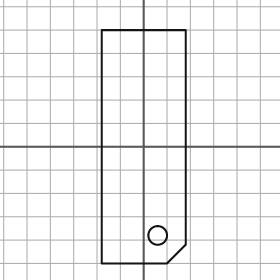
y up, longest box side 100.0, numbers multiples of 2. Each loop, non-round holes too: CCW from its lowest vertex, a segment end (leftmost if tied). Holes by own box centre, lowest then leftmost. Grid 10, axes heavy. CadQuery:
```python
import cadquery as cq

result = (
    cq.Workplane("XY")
    .moveTo(-18.0, -50.0)
    .lineTo(10.0, -50.0)
    .lineTo(18.0, -42.0)
    .lineTo(18.0, 50.0)
    .lineTo(-18.0, 50.0)
    .close()
    .moveTo(6.0, -38.0)
    .circle(4.0)
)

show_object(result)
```